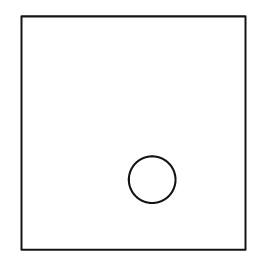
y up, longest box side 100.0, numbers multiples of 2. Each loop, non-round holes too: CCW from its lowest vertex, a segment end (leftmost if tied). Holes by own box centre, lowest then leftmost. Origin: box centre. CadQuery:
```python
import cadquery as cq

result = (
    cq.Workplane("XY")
    .moveTo(-48.0, -50.0)
    .lineTo(48.0, -50.0)
    .lineTo(48.0, 50.0)
    .lineTo(-48.0, 50.0)
    .close()
    .moveTo(8.0, -20.0)
    .circle(10.0)
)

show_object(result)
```